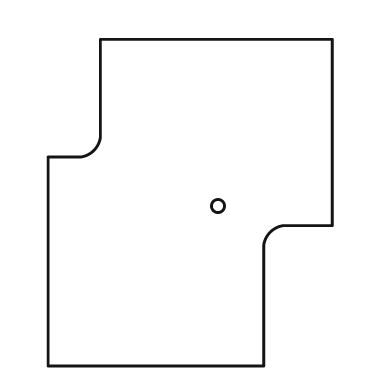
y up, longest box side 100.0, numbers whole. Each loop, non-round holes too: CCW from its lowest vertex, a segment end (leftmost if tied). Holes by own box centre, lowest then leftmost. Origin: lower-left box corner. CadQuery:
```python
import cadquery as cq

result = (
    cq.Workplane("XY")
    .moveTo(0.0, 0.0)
    .lineTo(66.0, 0.0)
    .lineTo(66.0, 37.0)
    .threePointArc((68.0, 41.0), (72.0, 43.0))
    .lineTo(87.0, 43.0)
    .lineTo(87.0, 100.0)
    .lineTo(16.0, 100.0)
    .lineTo(16.0, 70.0)
    .threePointArc((14.0, 66.0), (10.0, 64.0))
    .lineTo(0.0, 64.0)
    .close()
    .moveTo(52.0, 49.0)
    .circle(2.0)
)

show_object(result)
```